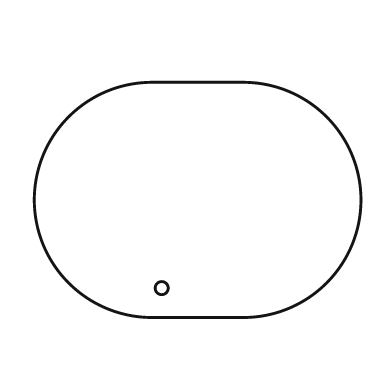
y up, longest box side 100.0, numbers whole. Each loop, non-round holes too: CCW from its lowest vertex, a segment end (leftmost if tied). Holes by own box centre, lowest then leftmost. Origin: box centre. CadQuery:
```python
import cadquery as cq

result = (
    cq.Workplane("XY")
    .moveTo(-14.0, -36.0)
    .lineTo(14.0, -36.0)
    .threePointArc((50.0, 0.0), (14.0, 36.0))
    .lineTo(-14.0, 36.0)
    .threePointArc((-50.0, 0.0), (-14.0, -36.0))
    .close()
    .moveTo(-11.0, -27.0)
    .circle(2.0)
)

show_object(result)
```